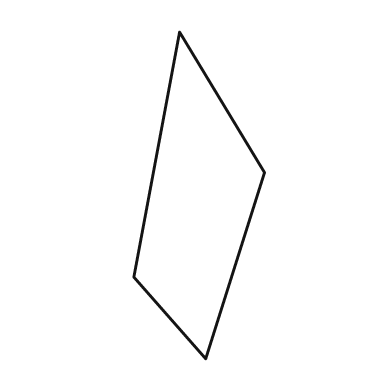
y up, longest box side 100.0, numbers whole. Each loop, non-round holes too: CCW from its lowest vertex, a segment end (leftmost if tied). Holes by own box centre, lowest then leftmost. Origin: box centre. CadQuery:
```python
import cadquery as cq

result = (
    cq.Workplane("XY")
    .moveTo(2.0, -50.0)
    .lineTo(20.0, 7.0)
    .lineTo(-6.0, 50.0)
    .lineTo(-20.0, -25.0)
    .close()
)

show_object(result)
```